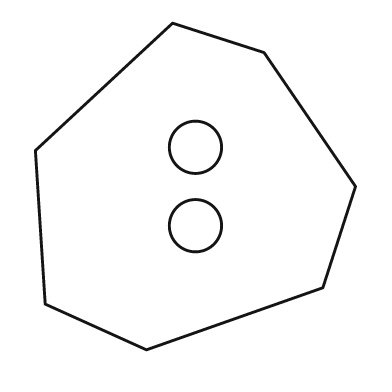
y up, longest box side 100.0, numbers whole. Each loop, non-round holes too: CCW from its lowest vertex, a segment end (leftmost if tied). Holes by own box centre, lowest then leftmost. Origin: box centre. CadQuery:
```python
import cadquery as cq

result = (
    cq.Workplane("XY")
    .moveTo(-15.0, -50.0)
    .lineTo(39.0, -31.0)
    .lineTo(49.0, 0.0)
    .lineTo(21.0, 41.0)
    .lineTo(-7.0, 50.0)
    .lineTo(-49.0, 11.0)
    .lineTo(-46.0, -36.0)
    .close()
    .moveTo(0.0, -12.0)
    .circle(8.0)
    .moveTo(0.0, 12.0)
    .circle(8.0)
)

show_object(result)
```